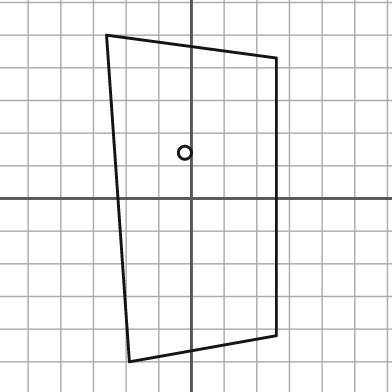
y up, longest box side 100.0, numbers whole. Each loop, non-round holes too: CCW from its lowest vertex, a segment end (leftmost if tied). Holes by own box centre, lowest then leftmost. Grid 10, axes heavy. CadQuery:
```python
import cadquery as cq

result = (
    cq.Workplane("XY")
    .moveTo(-19.0, -50.0)
    .lineTo(26.0, -42.0)
    .lineTo(26.0, 43.0)
    .lineTo(-26.0, 50.0)
    .close()
    .moveTo(-2.0, 14.0)
    .circle(2.0)
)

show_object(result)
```